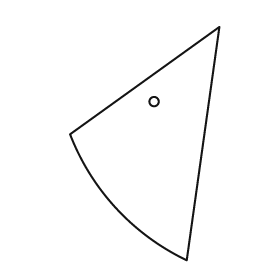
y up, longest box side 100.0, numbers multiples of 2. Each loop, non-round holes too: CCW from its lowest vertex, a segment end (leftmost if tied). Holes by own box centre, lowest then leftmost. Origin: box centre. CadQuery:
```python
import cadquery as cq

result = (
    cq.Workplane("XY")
    .moveTo(18.0, -50.0)
    .lineTo(32.0, 50.0)
    .lineTo(-32.0, 4.0)
    .threePointArc((-12.0, -28.0), (18.0, -50.0))
    .close()
    .moveTo(4.0, 18.0)
    .circle(2.0)
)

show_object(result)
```